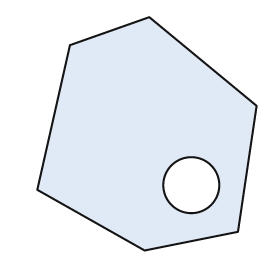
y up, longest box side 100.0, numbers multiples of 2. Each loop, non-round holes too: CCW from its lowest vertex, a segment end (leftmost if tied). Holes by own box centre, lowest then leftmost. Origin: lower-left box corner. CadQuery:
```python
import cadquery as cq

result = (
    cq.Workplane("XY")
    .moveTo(46.0, 0.0)
    .lineTo(86.0, 8.0)
    .lineTo(94.0, 62.0)
    .lineTo(48.0, 100.0)
    .lineTo(14.0, 88.0)
    .lineTo(0.0, 26.0)
    .close()
    .moveTo(66.0, 28.0)
    .circle(12.0)
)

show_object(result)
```